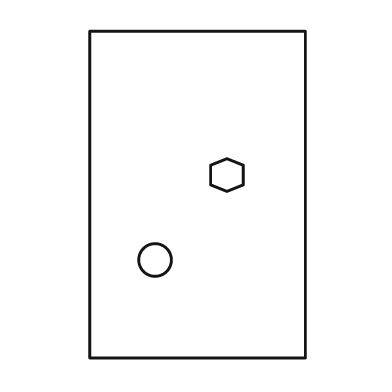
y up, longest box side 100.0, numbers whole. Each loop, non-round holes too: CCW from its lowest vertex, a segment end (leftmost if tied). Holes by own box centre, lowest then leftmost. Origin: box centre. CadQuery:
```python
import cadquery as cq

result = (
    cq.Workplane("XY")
    .moveTo(-33.0, -50.0)
    .lineTo(33.0, -50.0)
    .lineTo(33.0, 50.0)
    .lineTo(-33.0, 50.0)
    .close()
    .moveTo(-13.0, -20.0)
    .circle(5.0)
    .moveTo(9.0, 1.0)
    .lineTo(14.0, 3.0)
    .lineTo(14.0, 9.0)
    .lineTo(9.0, 11.0)
    .lineTo(4.0, 9.0)
    .lineTo(4.0, 3.0)
    .close()
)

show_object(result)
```